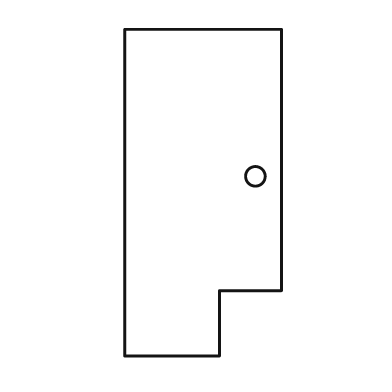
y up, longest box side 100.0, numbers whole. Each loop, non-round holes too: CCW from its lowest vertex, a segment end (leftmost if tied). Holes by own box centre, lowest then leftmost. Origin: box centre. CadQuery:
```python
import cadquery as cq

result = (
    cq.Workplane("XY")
    .moveTo(-24.0, -50.0)
    .lineTo(5.0, -50.0)
    .lineTo(5.0, -30.0)
    .lineTo(24.0, -30.0)
    .lineTo(24.0, 50.0)
    .lineTo(-24.0, 50.0)
    .close()
    .moveTo(16.0, 5.0)
    .circle(3.0)
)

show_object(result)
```